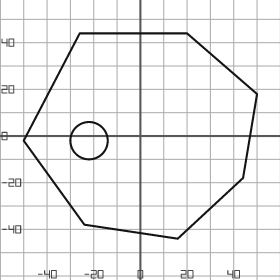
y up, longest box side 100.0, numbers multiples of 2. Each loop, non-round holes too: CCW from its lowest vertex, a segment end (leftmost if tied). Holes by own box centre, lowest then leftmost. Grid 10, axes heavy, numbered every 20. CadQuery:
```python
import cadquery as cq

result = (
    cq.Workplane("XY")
    .moveTo(16.0, -44.0)
    .lineTo(44.0, -18.0)
    .lineTo(50.0, 18.0)
    .lineTo(20.0, 44.0)
    .lineTo(-26.0, 44.0)
    .lineTo(-50.0, -2.0)
    .lineTo(-24.0, -38.0)
    .close()
    .moveTo(-22.0, -2.0)
    .circle(8.0)
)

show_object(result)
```